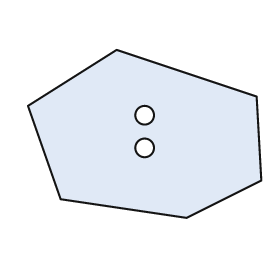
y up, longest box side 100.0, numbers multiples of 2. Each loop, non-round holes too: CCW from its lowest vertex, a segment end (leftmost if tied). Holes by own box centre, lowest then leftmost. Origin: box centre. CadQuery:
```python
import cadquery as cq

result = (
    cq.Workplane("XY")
    .moveTo(18.0, -36.0)
    .lineTo(50.0, -20.0)
    .lineTo(48.0, 16.0)
    .lineTo(-12.0, 36.0)
    .lineTo(-50.0, 12.0)
    .lineTo(-36.0, -28.0)
    .close()
    .moveTo(0.0, -6.0)
    .circle(4.0)
    .moveTo(0.0, 8.0)
    .circle(4.0)
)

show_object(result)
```